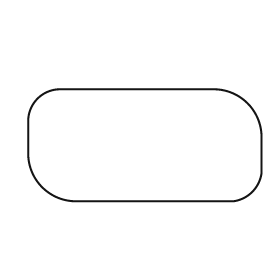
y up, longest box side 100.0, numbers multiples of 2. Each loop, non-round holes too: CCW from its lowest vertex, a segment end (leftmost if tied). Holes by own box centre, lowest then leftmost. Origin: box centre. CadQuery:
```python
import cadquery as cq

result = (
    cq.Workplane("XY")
    .moveTo(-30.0, -24.0)
    .lineTo(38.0, -24.0)
    .threePointArc((46.0, -20.0), (50.0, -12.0))
    .lineTo(50.0, 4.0)
    .threePointArc((44.0, 18.0), (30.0, 24.0))
    .lineTo(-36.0, 24.0)
    .threePointArc((-46.0, 20.0), (-50.0, 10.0))
    .lineTo(-50.0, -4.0)
    .threePointArc((-44.0, -18.0), (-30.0, -24.0))
    .close()
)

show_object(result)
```